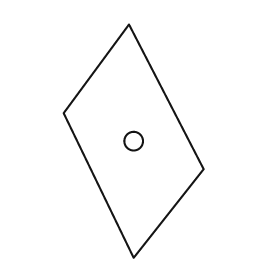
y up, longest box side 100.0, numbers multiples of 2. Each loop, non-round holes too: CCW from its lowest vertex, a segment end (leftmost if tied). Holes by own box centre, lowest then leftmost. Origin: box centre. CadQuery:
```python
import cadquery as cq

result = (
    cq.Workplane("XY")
    .moveTo(0.0, -50.0)
    .lineTo(30.0, -12.0)
    .lineTo(-2.0, 50.0)
    .lineTo(-30.0, 12.0)
    .close()
    .moveTo(0.0, 0.0)
    .circle(4.0)
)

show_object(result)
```